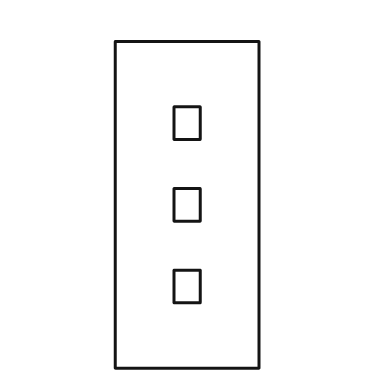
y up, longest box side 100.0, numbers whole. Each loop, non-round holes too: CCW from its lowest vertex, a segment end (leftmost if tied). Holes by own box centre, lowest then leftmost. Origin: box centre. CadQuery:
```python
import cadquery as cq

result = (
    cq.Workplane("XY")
    .moveTo(-22.0, -50.0)
    .lineTo(22.0, -50.0)
    .lineTo(22.0, 50.0)
    .lineTo(-22.0, 50.0)
    .close()
    .moveTo(-4.0, -30.0)
    .lineTo(4.0, -30.0)
    .lineTo(4.0, -20.0)
    .lineTo(-4.0, -20.0)
    .close()
    .moveTo(-4.0, -5.0)
    .lineTo(4.0, -5.0)
    .lineTo(4.0, 5.0)
    .lineTo(-4.0, 5.0)
    .close()
    .moveTo(-4.0, 20.0)
    .lineTo(4.0, 20.0)
    .lineTo(4.0, 30.0)
    .lineTo(-4.0, 30.0)
    .close()
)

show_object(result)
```